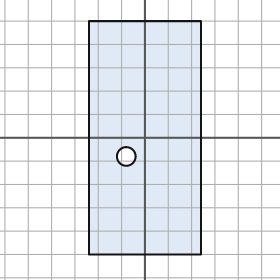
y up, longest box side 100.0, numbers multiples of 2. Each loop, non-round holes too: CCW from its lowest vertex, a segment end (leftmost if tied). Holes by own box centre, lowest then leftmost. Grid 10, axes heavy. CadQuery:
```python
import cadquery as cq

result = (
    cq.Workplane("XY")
    .moveTo(-24.0, -50.0)
    .lineTo(24.0, -50.0)
    .lineTo(24.0, 50.0)
    .lineTo(-24.0, 50.0)
    .close()
    .moveTo(-8.0, -8.0)
    .circle(4.0)
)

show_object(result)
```